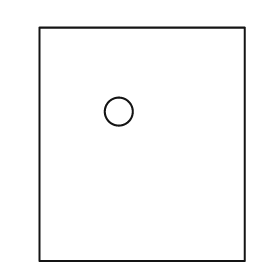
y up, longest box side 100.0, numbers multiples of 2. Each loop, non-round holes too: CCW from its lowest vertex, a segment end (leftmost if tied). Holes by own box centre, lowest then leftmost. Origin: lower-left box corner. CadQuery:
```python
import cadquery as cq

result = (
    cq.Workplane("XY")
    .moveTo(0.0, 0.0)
    .lineTo(88.0, 0.0)
    .lineTo(88.0, 100.0)
    .lineTo(0.0, 100.0)
    .close()
    .moveTo(34.0, 64.0)
    .circle(6.0)
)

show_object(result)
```